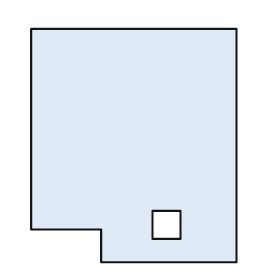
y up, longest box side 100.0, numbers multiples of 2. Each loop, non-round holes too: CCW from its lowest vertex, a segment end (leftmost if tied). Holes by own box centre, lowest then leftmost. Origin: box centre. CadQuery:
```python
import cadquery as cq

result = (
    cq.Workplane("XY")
    .moveTo(-14.0, -50.0)
    .lineTo(44.0, -50.0)
    .lineTo(44.0, 50.0)
    .lineTo(-44.0, 50.0)
    .lineTo(-44.0, -36.0)
    .lineTo(-14.0, -36.0)
    .close()
    .moveTo(8.0, -40.0)
    .lineTo(20.0, -40.0)
    .lineTo(20.0, -28.0)
    .lineTo(8.0, -28.0)
    .close()
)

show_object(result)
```